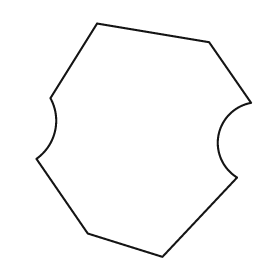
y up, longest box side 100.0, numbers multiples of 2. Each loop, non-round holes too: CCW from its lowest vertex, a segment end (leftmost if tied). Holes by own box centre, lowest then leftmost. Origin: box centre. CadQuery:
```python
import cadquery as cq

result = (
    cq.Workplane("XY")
    .moveTo(8.0, -50.0)
    .lineTo(40.0, -16.0)
    .threePointArc((32.0, 2.0), (46.0, 16.0))
    .lineTo(28.0, 42.0)
    .lineTo(-20.0, 50.0)
    .lineTo(-40.0, 18.0)
    .threePointArc((-38.0, 4.0), (-46.0, -8.0))
    .lineTo(-24.0, -40.0)
    .close()
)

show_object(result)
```